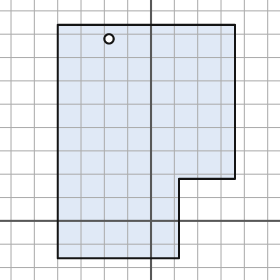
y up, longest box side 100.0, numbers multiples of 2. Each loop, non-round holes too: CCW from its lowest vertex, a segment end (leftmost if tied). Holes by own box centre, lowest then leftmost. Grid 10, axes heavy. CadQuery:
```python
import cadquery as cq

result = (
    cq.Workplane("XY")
    .moveTo(-40.0, -16.0)
    .lineTo(12.0, -16.0)
    .lineTo(12.0, 18.0)
    .lineTo(36.0, 18.0)
    .lineTo(36.0, 84.0)
    .lineTo(-40.0, 84.0)
    .close()
    .moveTo(-18.0, 78.0)
    .circle(2.0)
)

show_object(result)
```